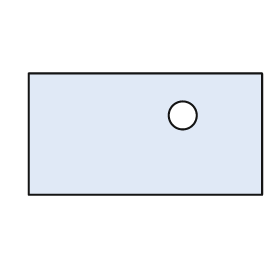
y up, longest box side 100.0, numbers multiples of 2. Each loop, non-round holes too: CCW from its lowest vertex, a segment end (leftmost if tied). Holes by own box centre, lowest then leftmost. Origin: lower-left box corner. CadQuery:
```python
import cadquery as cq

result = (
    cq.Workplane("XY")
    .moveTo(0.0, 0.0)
    .lineTo(100.0, 0.0)
    .lineTo(100.0, 52.0)
    .lineTo(0.0, 52.0)
    .close()
    .moveTo(66.0, 34.0)
    .circle(6.0)
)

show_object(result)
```